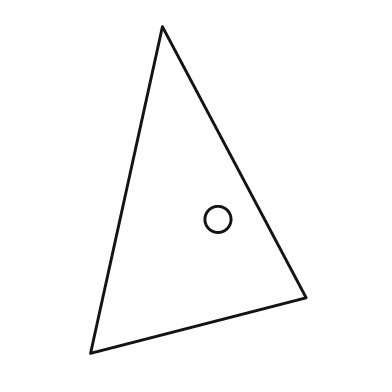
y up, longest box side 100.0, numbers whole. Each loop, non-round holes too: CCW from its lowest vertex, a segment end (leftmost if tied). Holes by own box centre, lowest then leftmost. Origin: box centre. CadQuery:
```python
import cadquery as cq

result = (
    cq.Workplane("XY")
    .moveTo(-33.0, -50.0)
    .lineTo(33.0, -33.0)
    .lineTo(-11.0, 50.0)
    .close()
    .moveTo(6.0, -9.0)
    .circle(4.0)
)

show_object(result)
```